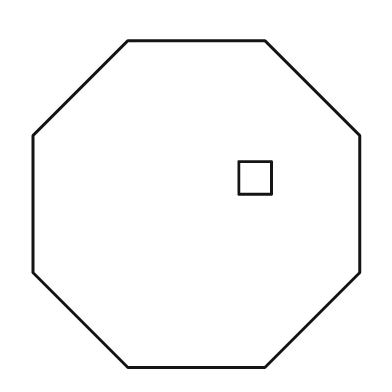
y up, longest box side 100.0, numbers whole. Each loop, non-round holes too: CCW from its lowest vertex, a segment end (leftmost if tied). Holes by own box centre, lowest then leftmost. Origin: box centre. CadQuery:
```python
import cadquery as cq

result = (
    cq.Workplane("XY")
    .moveTo(-21.0, -50.0)
    .lineTo(21.0, -50.0)
    .lineTo(50.0, -21.0)
    .lineTo(50.0, 21.0)
    .lineTo(21.0, 50.0)
    .lineTo(-21.0, 50.0)
    .lineTo(-50.0, 21.0)
    .lineTo(-50.0, -21.0)
    .close()
    .moveTo(13.0, 3.0)
    .lineTo(23.0, 3.0)
    .lineTo(23.0, 13.0)
    .lineTo(13.0, 13.0)
    .close()
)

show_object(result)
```